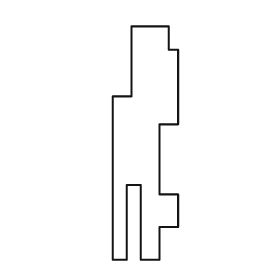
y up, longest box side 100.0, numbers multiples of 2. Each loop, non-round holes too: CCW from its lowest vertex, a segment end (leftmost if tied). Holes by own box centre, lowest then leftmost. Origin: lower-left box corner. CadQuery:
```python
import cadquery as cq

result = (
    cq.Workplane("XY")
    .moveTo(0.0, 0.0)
    .lineTo(6.0, 0.0)
    .lineTo(6.0, 32.0)
    .lineTo(12.0, 32.0)
    .lineTo(12.0, 0.0)
    .lineTo(20.0, 0.0)
    .lineTo(20.0, 14.0)
    .lineTo(28.0, 14.0)
    .lineTo(28.0, 28.0)
    .lineTo(20.0, 28.0)
    .lineTo(20.0, 58.0)
    .lineTo(28.0, 58.0)
    .lineTo(28.0, 90.0)
    .lineTo(24.0, 90.0)
    .lineTo(24.0, 100.0)
    .lineTo(8.0, 100.0)
    .lineTo(8.0, 70.0)
    .lineTo(0.0, 70.0)
    .close()
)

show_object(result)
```